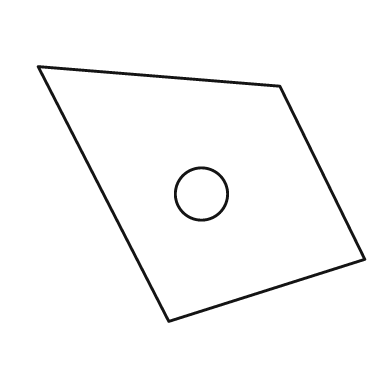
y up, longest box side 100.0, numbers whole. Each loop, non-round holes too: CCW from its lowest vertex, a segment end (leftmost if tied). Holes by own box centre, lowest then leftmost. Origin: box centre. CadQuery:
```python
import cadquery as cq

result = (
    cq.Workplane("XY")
    .moveTo(-10.0, -39.0)
    .lineTo(50.0, -20.0)
    .lineTo(24.0, 33.0)
    .lineTo(-50.0, 39.0)
    .close()
    .moveTo(0.0, 0.0)
    .circle(8.0)
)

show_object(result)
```